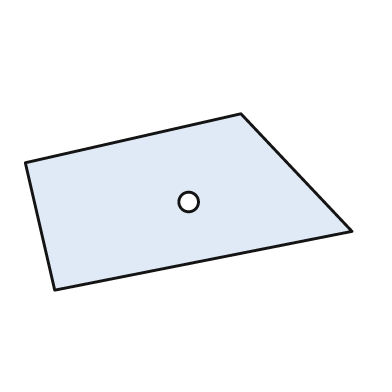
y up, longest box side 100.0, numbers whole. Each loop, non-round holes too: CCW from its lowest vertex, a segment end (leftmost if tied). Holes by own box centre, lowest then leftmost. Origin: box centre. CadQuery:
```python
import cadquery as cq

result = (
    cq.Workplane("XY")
    .moveTo(-41.0, -27.0)
    .lineTo(50.0, -9.0)
    .lineTo(16.0, 27.0)
    .lineTo(-50.0, 12.0)
    .close()
    .moveTo(0.0, 0.0)
    .circle(3.0)
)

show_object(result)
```